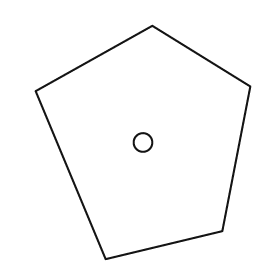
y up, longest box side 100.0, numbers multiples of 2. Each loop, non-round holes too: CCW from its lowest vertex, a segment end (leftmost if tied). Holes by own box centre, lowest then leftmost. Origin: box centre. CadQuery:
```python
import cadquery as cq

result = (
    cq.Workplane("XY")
    .moveTo(-16.0, -50.0)
    .lineTo(34.0, -38.0)
    .lineTo(46.0, 24.0)
    .lineTo(4.0, 50.0)
    .lineTo(-46.0, 22.0)
    .close()
    .moveTo(0.0, 0.0)
    .circle(4.0)
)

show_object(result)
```